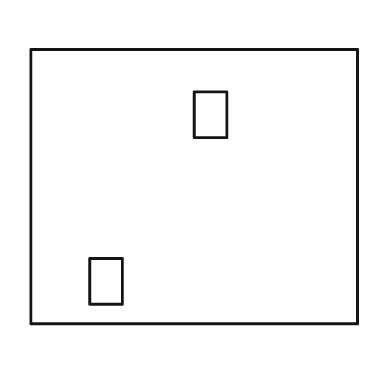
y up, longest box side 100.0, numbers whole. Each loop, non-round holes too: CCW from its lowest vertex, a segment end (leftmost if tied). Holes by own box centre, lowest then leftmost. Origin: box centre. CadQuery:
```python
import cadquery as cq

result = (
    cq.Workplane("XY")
    .moveTo(-50.0, -42.0)
    .lineTo(50.0, -42.0)
    .lineTo(50.0, 42.0)
    .lineTo(-50.0, 42.0)
    .close()
    .moveTo(-32.0, -36.0)
    .lineTo(-22.0, -36.0)
    .lineTo(-22.0, -22.0)
    .lineTo(-32.0, -22.0)
    .close()
    .moveTo(0.0, 15.0)
    .lineTo(10.0, 15.0)
    .lineTo(10.0, 29.0)
    .lineTo(0.0, 29.0)
    .close()
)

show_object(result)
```